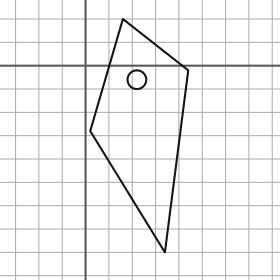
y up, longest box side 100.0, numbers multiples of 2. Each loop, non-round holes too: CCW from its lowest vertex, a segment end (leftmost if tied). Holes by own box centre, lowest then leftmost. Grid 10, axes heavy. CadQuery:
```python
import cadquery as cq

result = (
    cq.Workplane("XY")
    .moveTo(34.0, -80.0)
    .lineTo(44.0, -2.0)
    .lineTo(16.0, 20.0)
    .lineTo(2.0, -28.0)
    .close()
    .moveTo(22.0, -6.0)
    .circle(4.0)
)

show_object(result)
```